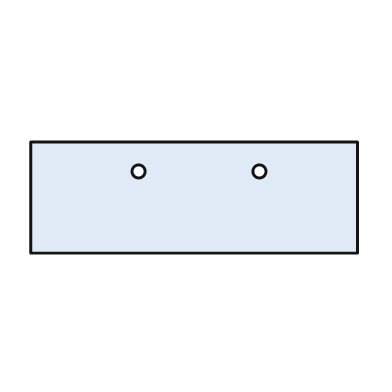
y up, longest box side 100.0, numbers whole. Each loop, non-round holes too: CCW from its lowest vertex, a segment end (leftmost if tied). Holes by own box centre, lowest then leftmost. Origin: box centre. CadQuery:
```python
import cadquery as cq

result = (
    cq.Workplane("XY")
    .moveTo(-50.0, -17.0)
    .lineTo(50.0, -17.0)
    .lineTo(50.0, 17.0)
    .lineTo(-50.0, 17.0)
    .close()
    .moveTo(-17.0, 8.0)
    .circle(2.0)
    .moveTo(20.0, 8.0)
    .circle(2.0)
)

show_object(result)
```